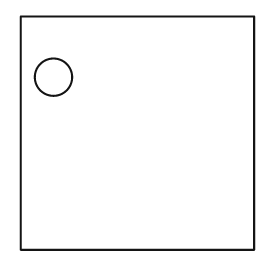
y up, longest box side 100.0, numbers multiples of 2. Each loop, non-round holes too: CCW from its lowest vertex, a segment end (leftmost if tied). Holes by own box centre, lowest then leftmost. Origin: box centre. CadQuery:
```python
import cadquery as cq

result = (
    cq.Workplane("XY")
    .moveTo(-50.0, -50.0)
    .lineTo(50.0, -50.0)
    .lineTo(50.0, 50.0)
    .lineTo(-50.0, 50.0)
    .close()
    .moveTo(-36.0, 24.0)
    .circle(8.0)
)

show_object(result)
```